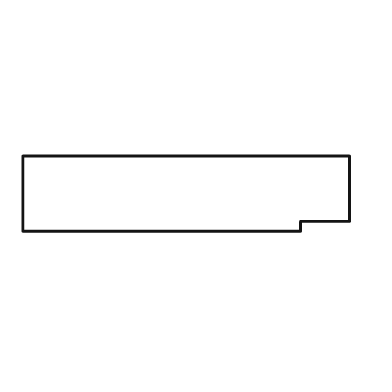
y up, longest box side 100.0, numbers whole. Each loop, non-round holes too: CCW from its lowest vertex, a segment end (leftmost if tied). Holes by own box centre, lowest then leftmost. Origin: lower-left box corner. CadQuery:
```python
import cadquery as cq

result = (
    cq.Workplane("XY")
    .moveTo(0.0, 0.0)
    .lineTo(85.0, 0.0)
    .lineTo(85.0, 3.0)
    .lineTo(100.0, 3.0)
    .lineTo(100.0, 23.0)
    .lineTo(0.0, 23.0)
    .close()
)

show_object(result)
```